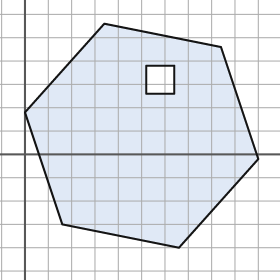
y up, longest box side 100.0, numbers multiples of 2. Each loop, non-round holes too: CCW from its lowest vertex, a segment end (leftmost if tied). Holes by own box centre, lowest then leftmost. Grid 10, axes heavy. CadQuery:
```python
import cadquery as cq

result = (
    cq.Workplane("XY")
    .moveTo(66.0, -40.0)
    .lineTo(100.0, -2.0)
    .lineTo(84.0, 46.0)
    .lineTo(34.0, 56.0)
    .lineTo(0.0, 18.0)
    .lineTo(16.0, -30.0)
    .close()
    .moveTo(52.0, 26.0)
    .lineTo(64.0, 26.0)
    .lineTo(64.0, 38.0)
    .lineTo(52.0, 38.0)
    .close()
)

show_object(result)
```